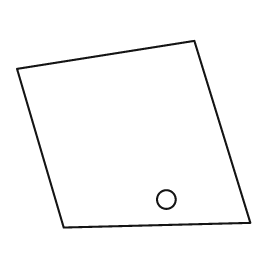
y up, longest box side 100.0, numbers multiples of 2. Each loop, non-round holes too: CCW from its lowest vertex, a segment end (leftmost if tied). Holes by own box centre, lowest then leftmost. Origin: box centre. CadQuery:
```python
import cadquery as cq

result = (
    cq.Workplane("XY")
    .moveTo(-30.0, -40.0)
    .lineTo(50.0, -38.0)
    .lineTo(26.0, 40.0)
    .lineTo(-50.0, 28.0)
    .close()
    .moveTo(14.0, -28.0)
    .circle(4.0)
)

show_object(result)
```